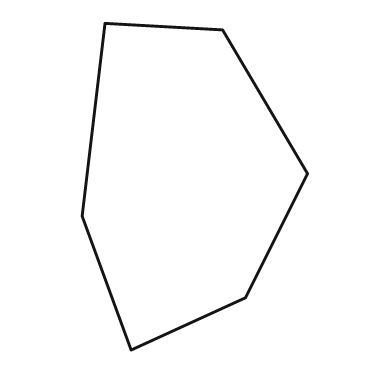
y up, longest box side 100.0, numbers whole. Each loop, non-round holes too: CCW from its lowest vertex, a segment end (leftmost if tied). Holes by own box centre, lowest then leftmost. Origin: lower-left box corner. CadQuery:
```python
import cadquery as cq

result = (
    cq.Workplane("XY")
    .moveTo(15.0, 0.0)
    .lineTo(50.0, 16.0)
    .lineTo(69.0, 54.0)
    .lineTo(43.0, 98.0)
    .lineTo(7.0, 100.0)
    .lineTo(0.0, 41.0)
    .close()
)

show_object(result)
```